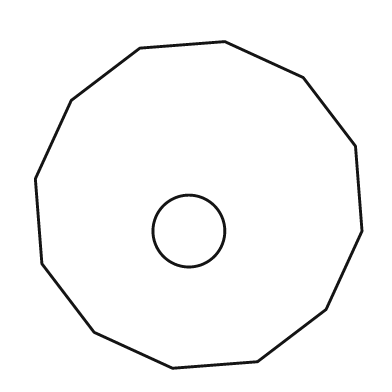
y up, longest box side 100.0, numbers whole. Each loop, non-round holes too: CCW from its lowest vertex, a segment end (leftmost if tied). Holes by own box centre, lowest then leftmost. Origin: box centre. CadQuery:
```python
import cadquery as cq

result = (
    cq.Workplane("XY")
    .moveTo(-8.0, -50.0)
    .lineTo(18.0, -48.0)
    .lineTo(39.0, -32.0)
    .lineTo(50.0, -8.0)
    .lineTo(48.0, 18.0)
    .lineTo(32.0, 39.0)
    .lineTo(8.0, 50.0)
    .lineTo(-18.0, 48.0)
    .lineTo(-39.0, 32.0)
    .lineTo(-50.0, 8.0)
    .lineTo(-48.0, -18.0)
    .lineTo(-32.0, -39.0)
    .close()
    .moveTo(-3.0, -8.0)
    .circle(11.0)
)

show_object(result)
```